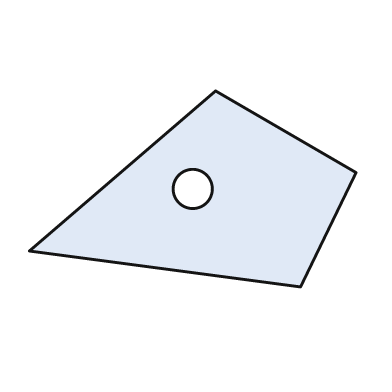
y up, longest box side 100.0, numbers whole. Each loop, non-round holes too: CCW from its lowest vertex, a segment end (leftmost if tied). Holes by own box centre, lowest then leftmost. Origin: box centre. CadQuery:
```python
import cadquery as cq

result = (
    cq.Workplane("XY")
    .moveTo(33.0, -30.0)
    .lineTo(50.0, 5.0)
    .lineTo(7.0, 30.0)
    .lineTo(-50.0, -19.0)
    .close()
    .moveTo(0.0, 0.0)
    .circle(6.0)
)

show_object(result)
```